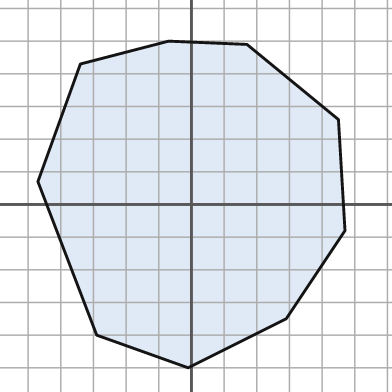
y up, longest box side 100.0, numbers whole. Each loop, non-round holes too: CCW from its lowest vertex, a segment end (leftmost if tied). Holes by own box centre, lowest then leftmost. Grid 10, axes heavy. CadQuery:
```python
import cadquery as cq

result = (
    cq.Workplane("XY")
    .moveTo(-1.0, -50.0)
    .lineTo(29.0, -35.0)
    .lineTo(47.0, -8.0)
    .lineTo(45.0, 26.0)
    .lineTo(17.0, 49.0)
    .lineTo(-7.0, 50.0)
    .lineTo(-34.0, 43.0)
    .lineTo(-47.0, 7.0)
    .lineTo(-29.0, -40.0)
    .close()
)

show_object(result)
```